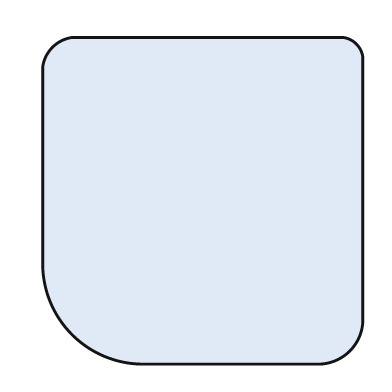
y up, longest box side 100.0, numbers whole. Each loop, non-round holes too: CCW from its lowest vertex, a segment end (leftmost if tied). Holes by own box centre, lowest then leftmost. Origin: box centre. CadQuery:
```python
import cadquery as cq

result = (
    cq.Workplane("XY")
    .moveTo(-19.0, -50.0)
    .lineTo(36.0, -50.0)
    .threePointArc((45.0, -46.0), (49.0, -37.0))
    .lineTo(49.0, 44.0)
    .threePointArc((47.0, 48.0), (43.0, 50.0))
    .lineTo(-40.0, 50.0)
    .threePointArc((-46.0, 47.0), (-49.0, 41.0))
    .lineTo(-49.0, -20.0)
    .threePointArc((-40.0, -41.0), (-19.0, -50.0))
    .close()
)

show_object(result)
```